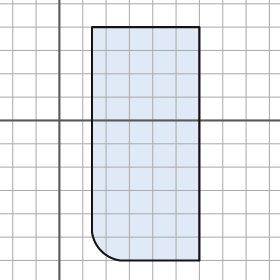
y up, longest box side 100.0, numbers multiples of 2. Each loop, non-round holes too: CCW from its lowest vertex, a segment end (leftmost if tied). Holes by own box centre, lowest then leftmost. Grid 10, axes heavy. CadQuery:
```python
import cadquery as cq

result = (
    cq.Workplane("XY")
    .moveTo(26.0, -60.0)
    .lineTo(60.0, -60.0)
    .lineTo(60.0, 40.0)
    .lineTo(14.0, 40.0)
    .lineTo(14.0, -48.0)
    .threePointArc((18.0, -56.0), (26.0, -60.0))
    .close()
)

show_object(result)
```